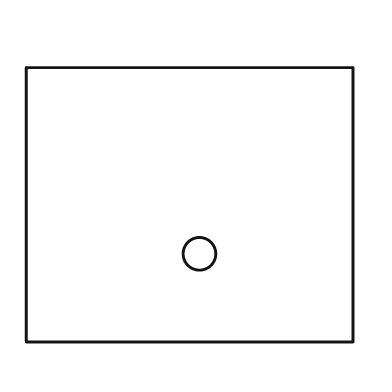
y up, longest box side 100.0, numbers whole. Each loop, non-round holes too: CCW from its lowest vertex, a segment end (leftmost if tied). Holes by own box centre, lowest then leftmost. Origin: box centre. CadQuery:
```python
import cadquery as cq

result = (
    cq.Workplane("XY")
    .moveTo(-50.0, -42.0)
    .lineTo(50.0, -42.0)
    .lineTo(50.0, 42.0)
    .lineTo(-50.0, 42.0)
    .close()
    .moveTo(3.0, -15.0)
    .circle(5.0)
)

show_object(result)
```